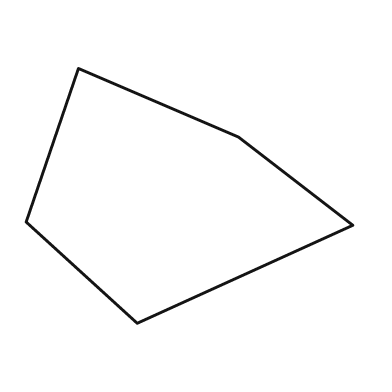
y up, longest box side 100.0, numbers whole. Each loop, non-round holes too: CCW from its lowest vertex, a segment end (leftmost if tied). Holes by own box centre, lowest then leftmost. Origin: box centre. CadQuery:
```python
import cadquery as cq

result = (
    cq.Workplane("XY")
    .moveTo(-16.0, -39.0)
    .lineTo(50.0, -9.0)
    .lineTo(15.0, 18.0)
    .lineTo(-34.0, 39.0)
    .lineTo(-50.0, -8.0)
    .close()
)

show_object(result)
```